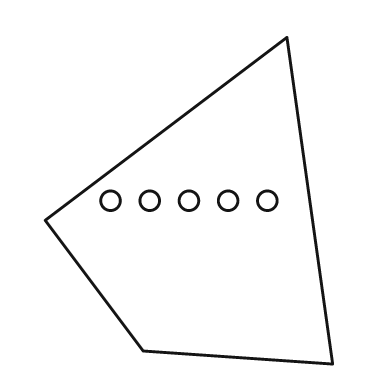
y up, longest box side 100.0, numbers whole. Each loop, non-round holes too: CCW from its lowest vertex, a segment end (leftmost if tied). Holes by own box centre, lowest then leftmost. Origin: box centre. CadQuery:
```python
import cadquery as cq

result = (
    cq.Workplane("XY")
    .moveTo(44.0, -50.0)
    .lineTo(30.0, 50.0)
    .lineTo(-44.0, -6.0)
    .lineTo(-14.0, -46.0)
    .close()
    .moveTo(-24.0, 0.0)
    .circle(3.0)
    .moveTo(-12.0, 0.0)
    .circle(3.0)
    .moveTo(0.0, 0.0)
    .circle(3.0)
    .moveTo(12.0, 0.0)
    .circle(3.0)
    .moveTo(24.0, 0.0)
    .circle(3.0)
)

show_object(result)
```